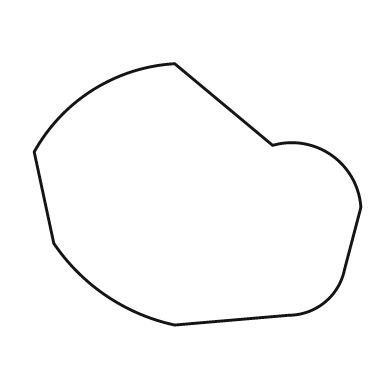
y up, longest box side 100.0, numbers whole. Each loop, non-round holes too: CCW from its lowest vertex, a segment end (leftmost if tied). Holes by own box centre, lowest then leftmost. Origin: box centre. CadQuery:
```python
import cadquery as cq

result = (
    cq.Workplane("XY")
    .moveTo(-7.0, -40.0)
    .lineTo(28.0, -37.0)
    .threePointArc((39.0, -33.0), (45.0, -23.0))
    .lineTo(50.0, -4.0)
    .threePointArc((41.0, 12.0), (23.0, 15.0))
    .lineTo(-7.0, 40.0)
    .threePointArc((-32.0, 32.0), (-50.0, 13.0))
    .lineTo(-44.0, -15.0)
    .threePointArc((-28.0, -31.0), (-7.0, -40.0))
    .close()
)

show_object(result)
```